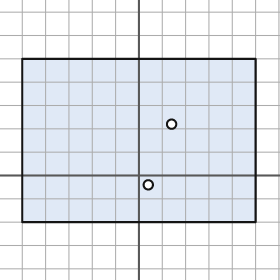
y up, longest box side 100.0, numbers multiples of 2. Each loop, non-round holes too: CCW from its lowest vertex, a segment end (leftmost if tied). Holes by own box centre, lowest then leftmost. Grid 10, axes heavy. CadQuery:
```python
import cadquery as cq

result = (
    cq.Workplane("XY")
    .moveTo(-50.0, -20.0)
    .lineTo(50.0, -20.0)
    .lineTo(50.0, 50.0)
    .lineTo(-50.0, 50.0)
    .close()
    .moveTo(4.0, -4.0)
    .circle(2.0)
    .moveTo(14.0, 22.0)
    .circle(2.0)
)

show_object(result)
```